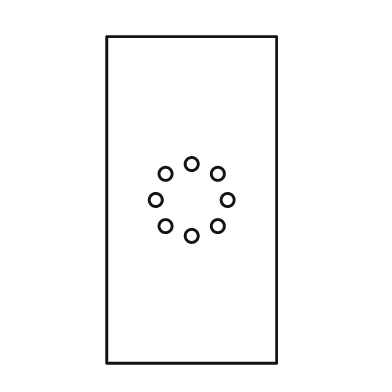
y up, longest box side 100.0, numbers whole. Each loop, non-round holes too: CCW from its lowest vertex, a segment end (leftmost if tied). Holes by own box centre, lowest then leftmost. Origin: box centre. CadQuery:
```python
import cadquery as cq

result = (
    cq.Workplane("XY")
    .moveTo(-26.0, -50.0)
    .lineTo(26.0, -50.0)
    .lineTo(26.0, 50.0)
    .lineTo(-26.0, 50.0)
    .close()
    .moveTo(0.0, -11.0)
    .circle(2.0)
    .moveTo(-8.0, -8.0)
    .circle(2.0)
    .moveTo(8.0, -8.0)
    .circle(2.0)
    .moveTo(-11.0, 0.0)
    .circle(2.0)
    .moveTo(11.0, 0.0)
    .circle(2.0)
    .moveTo(-8.0, 8.0)
    .circle(2.0)
    .moveTo(8.0, 8.0)
    .circle(2.0)
    .moveTo(0.0, 11.0)
    .circle(2.0)
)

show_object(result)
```